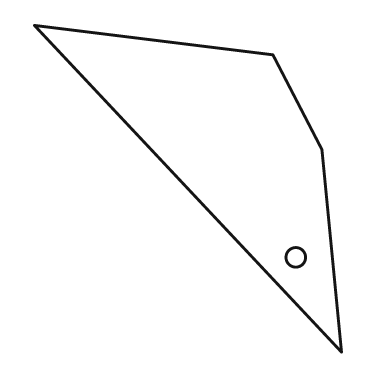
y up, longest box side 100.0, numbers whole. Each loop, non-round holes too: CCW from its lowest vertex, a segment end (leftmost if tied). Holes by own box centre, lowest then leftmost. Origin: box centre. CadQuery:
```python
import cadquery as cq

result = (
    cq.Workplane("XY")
    .moveTo(47.0, -50.0)
    .lineTo(41.0, 12.0)
    .lineTo(26.0, 41.0)
    .lineTo(-47.0, 50.0)
    .close()
    .moveTo(33.0, -21.0)
    .circle(3.0)
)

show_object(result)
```